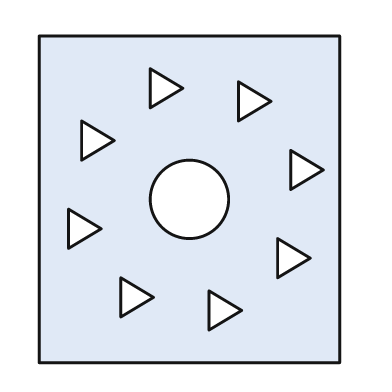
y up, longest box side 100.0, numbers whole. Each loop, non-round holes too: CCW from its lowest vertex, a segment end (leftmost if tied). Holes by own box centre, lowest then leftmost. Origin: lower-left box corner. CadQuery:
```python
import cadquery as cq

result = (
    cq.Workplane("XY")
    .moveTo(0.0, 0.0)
    .lineTo(92.0, 0.0)
    .lineTo(92.0, 100.0)
    .lineTo(0.0, 100.0)
    .close()
    .moveTo(52.0, 10.0)
    .lineTo(62.0, 16.0)
    .lineTo(52.0, 22.0)
    .close()
    .moveTo(25.0, 14.0)
    .lineTo(35.0, 20.0)
    .lineTo(25.0, 26.0)
    .close()
    .moveTo(73.0, 26.0)
    .lineTo(83.0, 32.0)
    .lineTo(73.0, 38.0)
    .close()
    .moveTo(9.0, 35.0)
    .lineTo(19.0, 41.0)
    .lineTo(9.0, 47.0)
    .close()
    .moveTo(46.0, 50.0)
    .circle(12.0)
    .moveTo(77.0, 53.0)
    .lineTo(87.0, 59.0)
    .lineTo(77.0, 65.0)
    .close()
    .moveTo(13.0, 62.0)
    .lineTo(23.0, 68.0)
    .lineTo(13.0, 74.0)
    .close()
    .moveTo(61.0, 74.0)
    .lineTo(71.0, 80.0)
    .lineTo(61.0, 86.0)
    .close()
    .moveTo(34.0, 78.0)
    .lineTo(44.0, 84.0)
    .lineTo(34.0, 90.0)
    .close()
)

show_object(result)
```